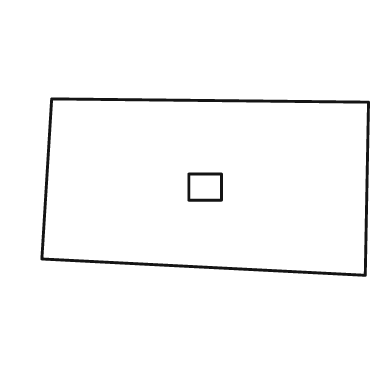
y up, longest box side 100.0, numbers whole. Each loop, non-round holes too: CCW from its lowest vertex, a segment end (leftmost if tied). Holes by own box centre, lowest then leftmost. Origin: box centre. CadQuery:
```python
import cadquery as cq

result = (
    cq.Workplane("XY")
    .moveTo(49.0, -27.0)
    .lineTo(50.0, 26.0)
    .lineTo(-47.0, 27.0)
    .lineTo(-50.0, -22.0)
    .close()
    .moveTo(-5.0, -4.0)
    .lineTo(5.0, -4.0)
    .lineTo(5.0, 4.0)
    .lineTo(-5.0, 4.0)
    .close()
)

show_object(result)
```